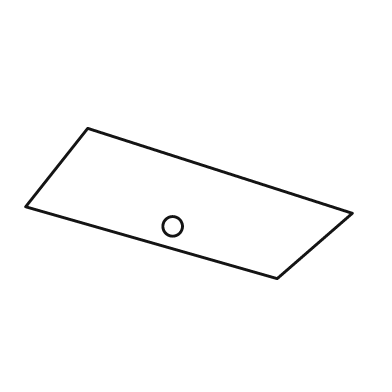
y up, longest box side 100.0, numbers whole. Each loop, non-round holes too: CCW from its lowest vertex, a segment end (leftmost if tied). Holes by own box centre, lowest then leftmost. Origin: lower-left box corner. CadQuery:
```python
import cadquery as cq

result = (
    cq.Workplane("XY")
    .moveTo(77.0, 0.0)
    .lineTo(100.0, 20.0)
    .lineTo(19.0, 46.0)
    .lineTo(0.0, 22.0)
    .close()
    .moveTo(45.0, 16.0)
    .circle(3.0)
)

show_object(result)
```